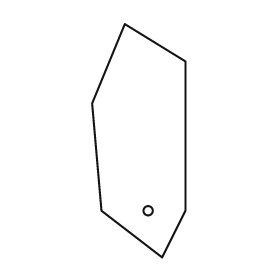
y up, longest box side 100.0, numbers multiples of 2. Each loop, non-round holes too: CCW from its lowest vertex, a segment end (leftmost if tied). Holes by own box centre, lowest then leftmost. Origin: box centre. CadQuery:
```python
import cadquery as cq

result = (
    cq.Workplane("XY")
    .moveTo(10.0, -50.0)
    .lineTo(20.0, -30.0)
    .lineTo(20.0, 34.0)
    .lineTo(-6.0, 50.0)
    .lineTo(-20.0, 16.0)
    .lineTo(-16.0, -30.0)
    .close()
    .moveTo(4.0, -30.0)
    .circle(2.0)
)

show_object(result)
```